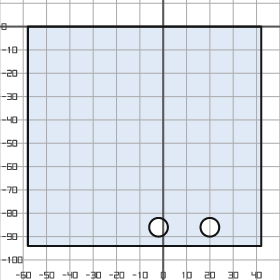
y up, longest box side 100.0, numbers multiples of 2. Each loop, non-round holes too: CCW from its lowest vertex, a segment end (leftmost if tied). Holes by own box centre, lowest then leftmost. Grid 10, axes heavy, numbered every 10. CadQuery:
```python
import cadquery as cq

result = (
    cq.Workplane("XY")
    .moveTo(-58.0, -94.0)
    .lineTo(42.0, -94.0)
    .lineTo(42.0, 0.0)
    .lineTo(-58.0, 0.0)
    .close()
    .moveTo(-2.0, -86.0)
    .circle(4.0)
    .moveTo(20.0, -86.0)
    .circle(4.0)
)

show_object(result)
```